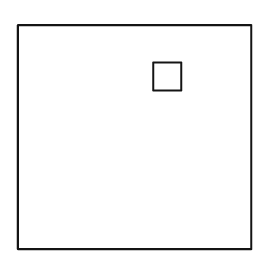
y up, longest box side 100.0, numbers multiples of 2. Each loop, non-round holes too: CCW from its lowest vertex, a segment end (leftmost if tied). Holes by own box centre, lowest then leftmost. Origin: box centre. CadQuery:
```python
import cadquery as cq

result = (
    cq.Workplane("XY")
    .moveTo(-50.0, -48.0)
    .lineTo(50.0, -48.0)
    .lineTo(50.0, 48.0)
    .lineTo(-50.0, 48.0)
    .close()
    .moveTo(8.0, 20.0)
    .lineTo(20.0, 20.0)
    .lineTo(20.0, 32.0)
    .lineTo(8.0, 32.0)
    .close()
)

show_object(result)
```